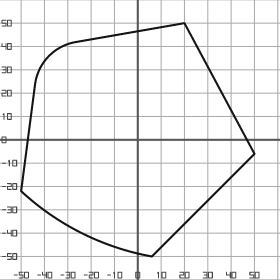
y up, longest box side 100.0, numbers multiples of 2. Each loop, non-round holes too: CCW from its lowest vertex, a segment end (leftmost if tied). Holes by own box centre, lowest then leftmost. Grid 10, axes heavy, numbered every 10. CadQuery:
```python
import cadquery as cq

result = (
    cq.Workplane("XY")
    .moveTo(6.0, -50.0)
    .lineTo(50.0, -6.0)
    .lineTo(20.0, 50.0)
    .lineTo(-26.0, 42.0)
    .threePointArc((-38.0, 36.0), (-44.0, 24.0))
    .lineTo(-50.0, -22.0)
    .threePointArc((-24.0, -40.0), (6.0, -50.0))
    .close()
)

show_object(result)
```